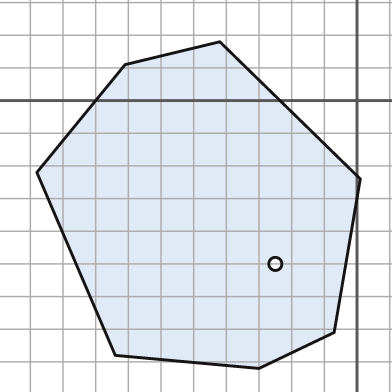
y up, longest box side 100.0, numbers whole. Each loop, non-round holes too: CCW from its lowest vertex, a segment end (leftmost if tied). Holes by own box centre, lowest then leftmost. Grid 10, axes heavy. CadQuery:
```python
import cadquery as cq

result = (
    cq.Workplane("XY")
    .moveTo(-30.0, -82.0)
    .lineTo(-7.0, -71.0)
    .lineTo(1.0, -24.0)
    .lineTo(-42.0, 18.0)
    .lineTo(-71.0, 11.0)
    .lineTo(-98.0, -22.0)
    .lineTo(-74.0, -78.0)
    .close()
    .moveTo(-25.0, -50.0)
    .circle(2.0)
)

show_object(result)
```